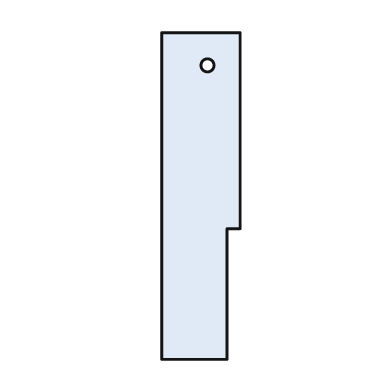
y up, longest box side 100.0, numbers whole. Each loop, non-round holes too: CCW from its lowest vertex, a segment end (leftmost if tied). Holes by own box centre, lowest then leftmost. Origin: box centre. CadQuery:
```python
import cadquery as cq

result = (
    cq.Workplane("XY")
    .moveTo(-12.0, -50.0)
    .lineTo(8.0, -50.0)
    .lineTo(8.0, -10.0)
    .lineTo(12.0, -10.0)
    .lineTo(12.0, 50.0)
    .lineTo(-12.0, 50.0)
    .close()
    .moveTo(2.0, 40.0)
    .circle(2.0)
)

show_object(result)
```